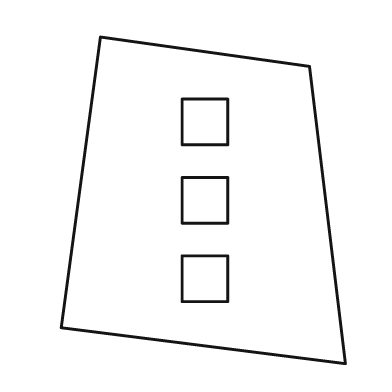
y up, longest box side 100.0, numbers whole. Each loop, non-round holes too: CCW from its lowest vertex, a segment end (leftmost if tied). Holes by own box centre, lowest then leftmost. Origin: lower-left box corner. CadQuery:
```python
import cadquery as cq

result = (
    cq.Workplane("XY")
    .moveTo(87.0, 0.0)
    .lineTo(76.0, 91.0)
    .lineTo(12.0, 100.0)
    .lineTo(0.0, 11.0)
    .close()
    .moveTo(37.0, 19.0)
    .lineTo(51.0, 19.0)
    .lineTo(51.0, 33.0)
    .lineTo(37.0, 33.0)
    .close()
    .moveTo(37.0, 43.0)
    .lineTo(51.0, 43.0)
    .lineTo(51.0, 57.0)
    .lineTo(37.0, 57.0)
    .close()
    .moveTo(37.0, 67.0)
    .lineTo(51.0, 67.0)
    .lineTo(51.0, 81.0)
    .lineTo(37.0, 81.0)
    .close()
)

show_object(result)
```